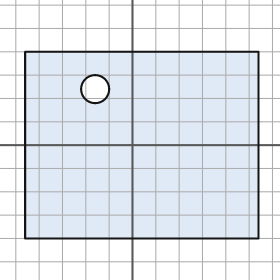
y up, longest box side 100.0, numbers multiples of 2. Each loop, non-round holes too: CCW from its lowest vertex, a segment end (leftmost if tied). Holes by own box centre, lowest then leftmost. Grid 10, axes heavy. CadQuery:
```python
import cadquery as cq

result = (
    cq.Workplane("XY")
    .moveTo(-46.0, -40.0)
    .lineTo(54.0, -40.0)
    .lineTo(54.0, 40.0)
    .lineTo(-46.0, 40.0)
    .close()
    .moveTo(-16.0, 24.0)
    .circle(6.0)
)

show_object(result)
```